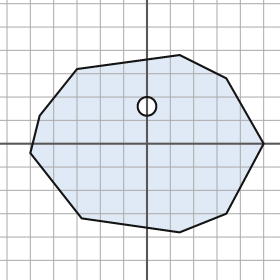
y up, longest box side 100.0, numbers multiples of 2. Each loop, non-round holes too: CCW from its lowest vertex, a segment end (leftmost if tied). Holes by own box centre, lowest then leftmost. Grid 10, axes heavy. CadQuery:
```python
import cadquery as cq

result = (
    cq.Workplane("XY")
    .moveTo(14.0, -38.0)
    .lineTo(34.0, -30.0)
    .lineTo(50.0, 0.0)
    .lineTo(34.0, 28.0)
    .lineTo(14.0, 38.0)
    .lineTo(-30.0, 32.0)
    .lineTo(-46.0, 12.0)
    .lineTo(-50.0, -4.0)
    .lineTo(-28.0, -32.0)
    .close()
    .moveTo(0.0, 16.0)
    .circle(4.0)
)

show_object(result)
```